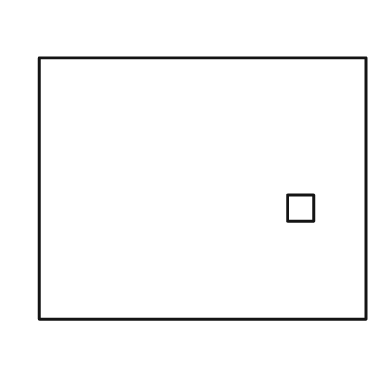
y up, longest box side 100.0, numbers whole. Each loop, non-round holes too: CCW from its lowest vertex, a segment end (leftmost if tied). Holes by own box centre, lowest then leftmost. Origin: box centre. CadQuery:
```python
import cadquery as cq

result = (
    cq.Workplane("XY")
    .moveTo(-50.0, -40.0)
    .lineTo(50.0, -40.0)
    .lineTo(50.0, 40.0)
    .lineTo(-50.0, 40.0)
    .close()
    .moveTo(26.0, -10.0)
    .lineTo(34.0, -10.0)
    .lineTo(34.0, -2.0)
    .lineTo(26.0, -2.0)
    .close()
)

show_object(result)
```